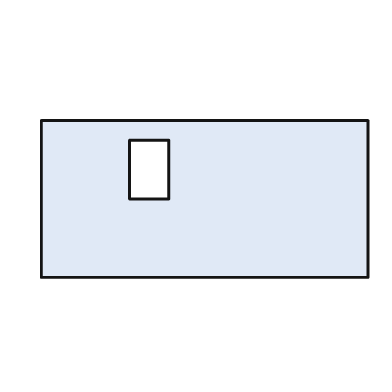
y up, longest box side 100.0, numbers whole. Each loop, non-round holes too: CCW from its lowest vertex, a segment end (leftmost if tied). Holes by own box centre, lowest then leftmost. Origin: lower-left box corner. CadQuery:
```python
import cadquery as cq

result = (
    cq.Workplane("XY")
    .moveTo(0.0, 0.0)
    .lineTo(100.0, 0.0)
    .lineTo(100.0, 48.0)
    .lineTo(0.0, 48.0)
    .close()
    .moveTo(27.0, 24.0)
    .lineTo(39.0, 24.0)
    .lineTo(39.0, 42.0)
    .lineTo(27.0, 42.0)
    .close()
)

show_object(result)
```